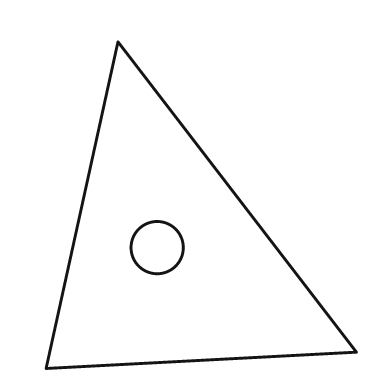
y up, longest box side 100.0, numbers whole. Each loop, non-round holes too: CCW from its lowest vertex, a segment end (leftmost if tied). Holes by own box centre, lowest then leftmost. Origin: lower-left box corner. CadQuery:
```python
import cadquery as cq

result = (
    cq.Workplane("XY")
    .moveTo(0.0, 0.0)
    .lineTo(95.0, 5.0)
    .lineTo(22.0, 100.0)
    .close()
    .moveTo(34.0, 37.0)
    .circle(8.0)
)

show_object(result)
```